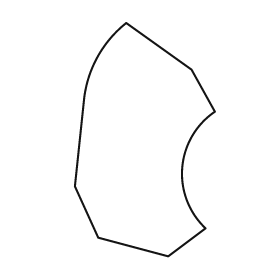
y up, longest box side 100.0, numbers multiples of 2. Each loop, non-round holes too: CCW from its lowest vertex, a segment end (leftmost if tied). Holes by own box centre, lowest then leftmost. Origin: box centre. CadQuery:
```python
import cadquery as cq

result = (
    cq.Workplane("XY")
    .moveTo(10.0, -50.0)
    .lineTo(26.0, -38.0)
    .threePointArc((16.0, -12.0), (30.0, 12.0))
    .lineTo(20.0, 30.0)
    .lineTo(-8.0, 50.0)
    .threePointArc((-20.0, 36.0), (-26.0, 18.0))
    .lineTo(-30.0, -20.0)
    .lineTo(-20.0, -42.0)
    .close()
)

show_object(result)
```